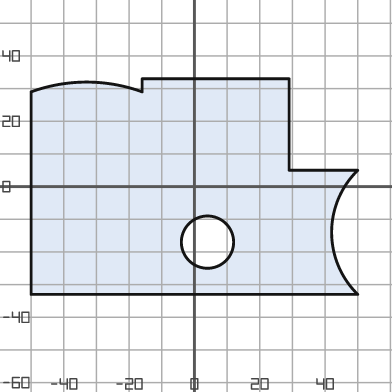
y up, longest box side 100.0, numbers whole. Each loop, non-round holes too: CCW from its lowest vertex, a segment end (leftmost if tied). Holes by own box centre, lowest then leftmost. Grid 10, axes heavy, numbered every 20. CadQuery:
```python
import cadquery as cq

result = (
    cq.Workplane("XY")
    .moveTo(-50.0, -33.0)
    .lineTo(50.0, -33.0)
    .threePointArc((42.0, -14.0), (50.0, 5.0))
    .lineTo(29.0, 5.0)
    .lineTo(29.0, 33.0)
    .lineTo(-16.0, 33.0)
    .lineTo(-16.0, 29.0)
    .threePointArc((-33.0, 32.0), (-50.0, 29.0))
    .close()
    .moveTo(4.0, -17.0)
    .circle(8.0)
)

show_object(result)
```